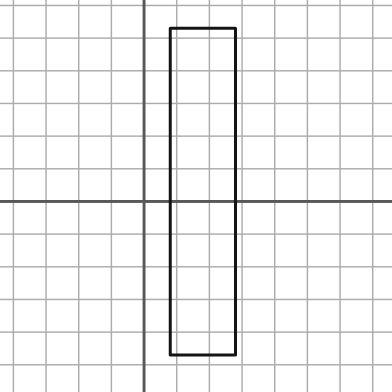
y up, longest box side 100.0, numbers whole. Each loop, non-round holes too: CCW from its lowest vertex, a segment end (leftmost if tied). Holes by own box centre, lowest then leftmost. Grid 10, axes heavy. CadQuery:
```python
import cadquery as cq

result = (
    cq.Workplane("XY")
    .moveTo(8.0, -47.0)
    .lineTo(28.0, -47.0)
    .lineTo(28.0, 53.0)
    .lineTo(8.0, 53.0)
    .close()
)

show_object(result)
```